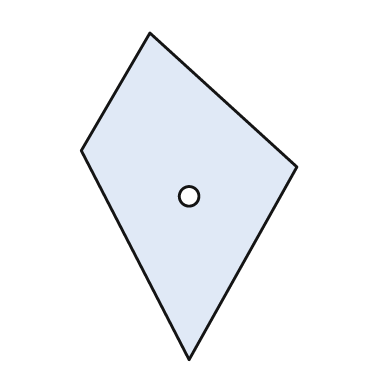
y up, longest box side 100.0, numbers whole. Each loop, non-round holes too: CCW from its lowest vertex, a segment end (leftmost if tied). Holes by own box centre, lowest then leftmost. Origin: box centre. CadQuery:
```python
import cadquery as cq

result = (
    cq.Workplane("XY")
    .moveTo(0.0, -50.0)
    .lineTo(33.0, 9.0)
    .lineTo(-12.0, 50.0)
    .lineTo(-33.0, 14.0)
    .close()
    .moveTo(0.0, 0.0)
    .circle(3.0)
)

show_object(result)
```